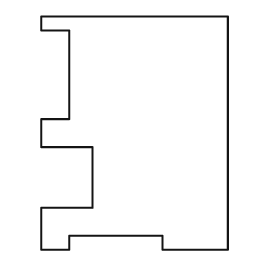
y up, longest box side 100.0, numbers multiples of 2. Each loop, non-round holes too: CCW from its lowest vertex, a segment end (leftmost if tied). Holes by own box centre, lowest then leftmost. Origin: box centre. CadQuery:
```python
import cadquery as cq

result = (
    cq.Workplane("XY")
    .moveTo(-40.0, -50.0)
    .lineTo(-28.0, -50.0)
    .lineTo(-28.0, -44.0)
    .lineTo(12.0, -44.0)
    .lineTo(12.0, -50.0)
    .lineTo(40.0, -50.0)
    .lineTo(40.0, 50.0)
    .lineTo(-40.0, 50.0)
    .lineTo(-40.0, 44.0)
    .lineTo(-28.0, 44.0)
    .lineTo(-28.0, 6.0)
    .lineTo(-40.0, 6.0)
    .lineTo(-40.0, -6.0)
    .lineTo(-18.0, -6.0)
    .lineTo(-18.0, -32.0)
    .lineTo(-40.0, -32.0)
    .close()
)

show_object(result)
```